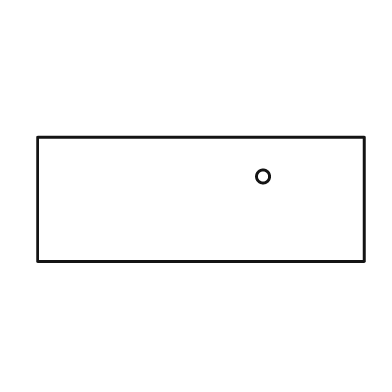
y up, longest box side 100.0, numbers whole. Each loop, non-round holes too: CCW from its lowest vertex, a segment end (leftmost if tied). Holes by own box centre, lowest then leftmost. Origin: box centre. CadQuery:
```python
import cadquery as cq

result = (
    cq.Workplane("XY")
    .moveTo(-50.0, -19.0)
    .lineTo(50.0, -19.0)
    .lineTo(50.0, 19.0)
    .lineTo(-50.0, 19.0)
    .close()
    .moveTo(19.0, 7.0)
    .circle(2.0)
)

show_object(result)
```